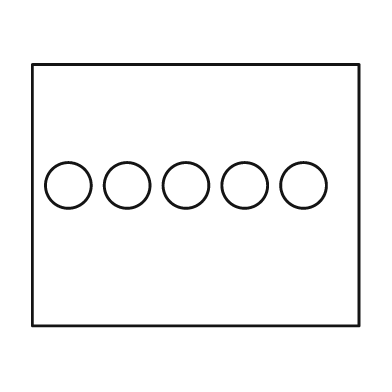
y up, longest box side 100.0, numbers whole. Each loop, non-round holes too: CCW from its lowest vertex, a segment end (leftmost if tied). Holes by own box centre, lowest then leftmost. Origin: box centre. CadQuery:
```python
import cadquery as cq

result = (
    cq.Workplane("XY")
    .moveTo(-50.0, -40.0)
    .lineTo(50.0, -40.0)
    .lineTo(50.0, 40.0)
    .lineTo(-50.0, 40.0)
    .close()
    .moveTo(-39.0, 3.0)
    .circle(7.0)
    .moveTo(-21.0, 3.0)
    .circle(7.0)
    .moveTo(-3.0, 3.0)
    .circle(7.0)
    .moveTo(15.0, 3.0)
    .circle(7.0)
    .moveTo(33.0, 3.0)
    .circle(7.0)
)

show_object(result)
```